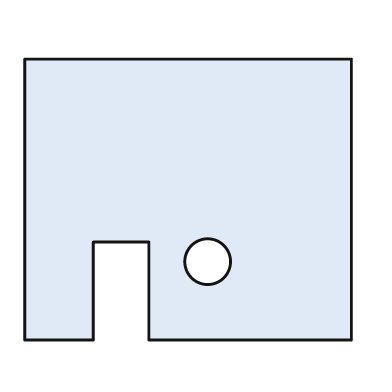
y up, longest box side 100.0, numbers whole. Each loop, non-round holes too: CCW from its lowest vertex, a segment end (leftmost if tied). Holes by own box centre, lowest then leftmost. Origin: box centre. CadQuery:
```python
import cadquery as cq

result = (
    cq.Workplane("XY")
    .moveTo(-50.0, -43.0)
    .lineTo(-29.0, -43.0)
    .lineTo(-29.0, -13.0)
    .lineTo(-12.0, -13.0)
    .lineTo(-12.0, -43.0)
    .lineTo(50.0, -43.0)
    .lineTo(50.0, 43.0)
    .lineTo(-50.0, 43.0)
    .close()
    .moveTo(6.0, -19.0)
    .circle(7.0)
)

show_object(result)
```